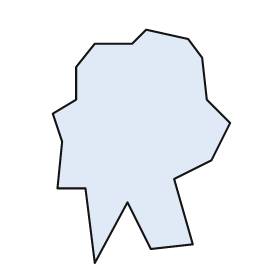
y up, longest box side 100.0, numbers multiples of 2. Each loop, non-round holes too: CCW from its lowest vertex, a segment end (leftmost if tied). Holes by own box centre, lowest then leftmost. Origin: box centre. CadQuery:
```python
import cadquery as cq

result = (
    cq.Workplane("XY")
    .moveTo(-20.0, -50.0)
    .lineTo(-6.0, -24.0)
    .lineTo(4.0, -44.0)
    .lineTo(22.0, -42.0)
    .lineTo(14.0, -14.0)
    .lineTo(30.0, -6.0)
    .lineTo(38.0, 10.0)
    .lineTo(28.0, 20.0)
    .lineTo(26.0, 38.0)
    .lineTo(20.0, 46.0)
    .lineTo(2.0, 50.0)
    .lineTo(-4.0, 44.0)
    .lineTo(-20.0, 44.0)
    .lineTo(-28.0, 34.0)
    .lineTo(-28.0, 20.0)
    .lineTo(-38.0, 14.0)
    .lineTo(-34.0, 2.0)
    .lineTo(-36.0, -18.0)
    .lineTo(-24.0, -18.0)
    .close()
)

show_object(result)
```